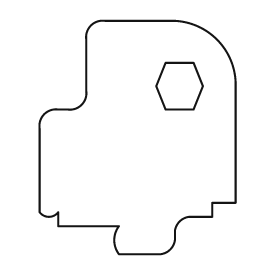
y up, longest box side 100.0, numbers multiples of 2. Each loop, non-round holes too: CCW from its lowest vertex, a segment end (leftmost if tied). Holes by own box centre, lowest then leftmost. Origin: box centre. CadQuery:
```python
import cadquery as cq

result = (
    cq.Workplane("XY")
    .moveTo(-8.0, -50.0)
    .lineTo(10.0, -50.0)
    .threePointArc((14.0, -48.0), (16.0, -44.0))
    .lineTo(16.0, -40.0)
    .threePointArc((18.0, -36.0), (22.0, -34.0))
    .lineTo(32.0, -34.0)
    .lineTo(32.0, -28.0)
    .lineTo(42.0, -28.0)
    .lineTo(42.0, 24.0)
    .threePointArc((34.0, 42.0), (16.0, 50.0))
    .lineTo(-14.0, 50.0)
    .threePointArc((-20.0, 48.0), (-22.0, 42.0))
    .lineTo(-22.0, 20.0)
    .threePointArc((-24.0, 14.0), (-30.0, 12.0))
    .lineTo(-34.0, 12.0)
    .threePointArc((-40.0, 10.0), (-42.0, 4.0))
    .lineTo(-42.0, -32.0)
    .threePointArc((-38.0, -34.0), (-34.0, -32.0))
    .lineTo(-34.0, -38.0)
    .lineTo(-8.0, -38.0)
    .threePointArc((-10.0, -44.0), (-8.0, -50.0))
    .close()
    .moveTo(12.0, 12.0)
    .lineTo(24.0, 12.0)
    .lineTo(28.0, 22.0)
    .lineTo(24.0, 32.0)
    .lineTo(12.0, 32.0)
    .lineTo(8.0, 22.0)
    .close()
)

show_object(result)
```